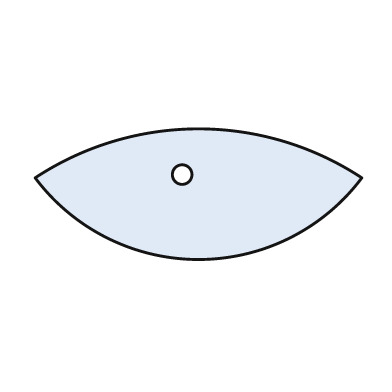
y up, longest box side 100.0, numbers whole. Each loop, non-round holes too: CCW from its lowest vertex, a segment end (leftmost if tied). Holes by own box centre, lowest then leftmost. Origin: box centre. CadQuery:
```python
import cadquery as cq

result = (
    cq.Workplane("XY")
    .moveTo(-50.0, 5.0)
    .threePointArc((0.0, -20.0), (50.0, 5.0))
    .threePointArc((0.0, 20.0), (-50.0, 5.0))
    .close()
    .moveTo(-5.0, 6.0)
    .circle(3.0)
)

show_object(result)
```